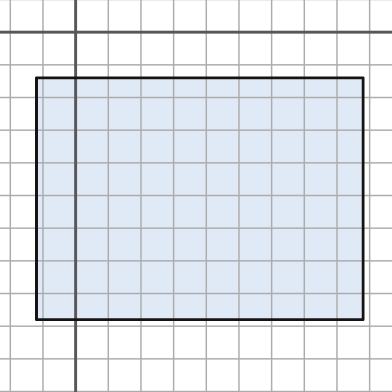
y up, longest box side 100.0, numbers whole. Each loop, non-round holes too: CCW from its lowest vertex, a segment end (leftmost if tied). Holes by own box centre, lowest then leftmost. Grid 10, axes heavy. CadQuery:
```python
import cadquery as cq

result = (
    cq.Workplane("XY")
    .moveTo(-12.0, -88.0)
    .lineTo(88.0, -88.0)
    .lineTo(88.0, -14.0)
    .lineTo(-12.0, -14.0)
    .close()
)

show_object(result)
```